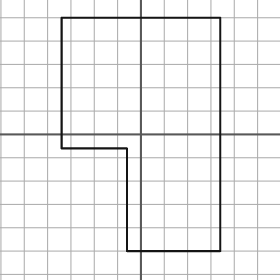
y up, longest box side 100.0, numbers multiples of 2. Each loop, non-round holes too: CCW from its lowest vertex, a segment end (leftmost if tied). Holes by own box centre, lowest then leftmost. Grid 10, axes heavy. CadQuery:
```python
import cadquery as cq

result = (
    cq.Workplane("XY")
    .moveTo(-6.0, -50.0)
    .lineTo(34.0, -50.0)
    .lineTo(34.0, 50.0)
    .lineTo(-34.0, 50.0)
    .lineTo(-34.0, -6.0)
    .lineTo(-6.0, -6.0)
    .close()
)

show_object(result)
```